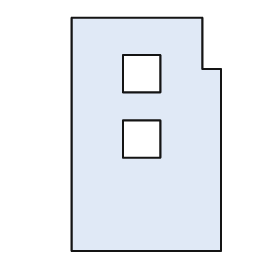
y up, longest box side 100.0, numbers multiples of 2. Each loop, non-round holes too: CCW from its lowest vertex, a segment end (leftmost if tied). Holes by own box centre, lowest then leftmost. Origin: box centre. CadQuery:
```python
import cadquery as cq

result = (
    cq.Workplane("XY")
    .moveTo(-32.0, -50.0)
    .lineTo(32.0, -50.0)
    .lineTo(32.0, 28.0)
    .lineTo(24.0, 28.0)
    .lineTo(24.0, 50.0)
    .lineTo(-32.0, 50.0)
    .close()
    .moveTo(-10.0, -10.0)
    .lineTo(6.0, -10.0)
    .lineTo(6.0, 6.0)
    .lineTo(-10.0, 6.0)
    .close()
    .moveTo(-10.0, 18.0)
    .lineTo(6.0, 18.0)
    .lineTo(6.0, 34.0)
    .lineTo(-10.0, 34.0)
    .close()
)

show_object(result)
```